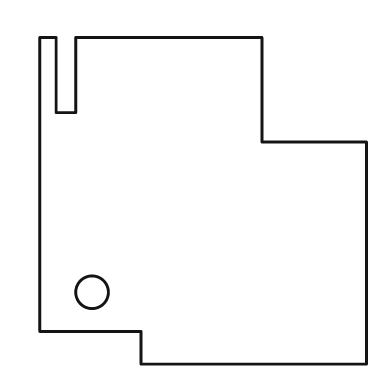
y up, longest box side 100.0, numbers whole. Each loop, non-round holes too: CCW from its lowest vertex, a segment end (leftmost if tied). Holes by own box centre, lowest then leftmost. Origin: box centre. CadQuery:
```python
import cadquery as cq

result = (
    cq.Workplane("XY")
    .moveTo(-19.0, -50.0)
    .lineTo(50.0, -50.0)
    .lineTo(50.0, 18.0)
    .lineTo(18.0, 18.0)
    .lineTo(18.0, 50.0)
    .lineTo(-39.0, 50.0)
    .lineTo(-39.0, 27.0)
    .lineTo(-45.0, 27.0)
    .lineTo(-45.0, 50.0)
    .lineTo(-50.0, 50.0)
    .lineTo(-50.0, -40.0)
    .lineTo(-19.0, -40.0)
    .close()
    .moveTo(-34.0, -28.0)
    .circle(5.0)
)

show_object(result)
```